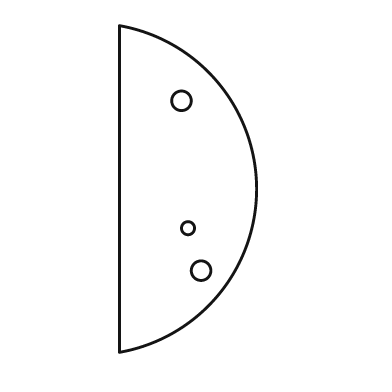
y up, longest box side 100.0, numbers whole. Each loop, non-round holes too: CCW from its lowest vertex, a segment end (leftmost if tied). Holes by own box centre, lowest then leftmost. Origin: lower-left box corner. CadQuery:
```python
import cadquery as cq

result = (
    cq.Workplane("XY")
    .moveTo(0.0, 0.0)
    .threePointArc((42.0, 50.0), (0.0, 100.0))
    .close()
    .moveTo(25.0, 25.0)
    .circle(3.0)
    .moveTo(21.0, 38.0)
    .circle(2.0)
    .moveTo(19.0, 77.0)
    .circle(3.0)
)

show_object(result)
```